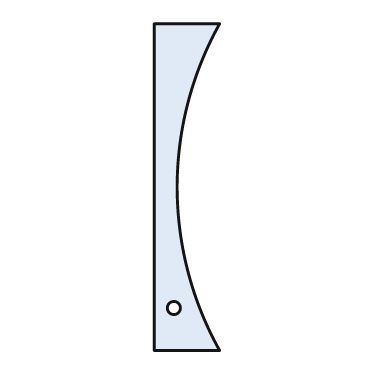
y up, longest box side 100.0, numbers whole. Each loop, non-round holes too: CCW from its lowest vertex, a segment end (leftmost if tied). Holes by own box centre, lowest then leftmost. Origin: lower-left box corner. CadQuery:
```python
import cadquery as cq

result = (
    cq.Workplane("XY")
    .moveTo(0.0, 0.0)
    .lineTo(20.0, 0.0)
    .threePointArc((7.0, 50.0), (20.0, 100.0))
    .lineTo(0.0, 100.0)
    .close()
    .moveTo(6.0, 13.0)
    .circle(2.0)
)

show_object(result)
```